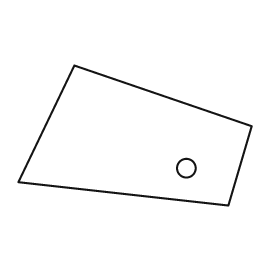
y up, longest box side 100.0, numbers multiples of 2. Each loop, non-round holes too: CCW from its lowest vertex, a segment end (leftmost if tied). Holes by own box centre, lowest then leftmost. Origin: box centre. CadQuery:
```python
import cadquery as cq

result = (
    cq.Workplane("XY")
    .moveTo(40.0, -30.0)
    .lineTo(50.0, 4.0)
    .lineTo(-26.0, 30.0)
    .lineTo(-50.0, -20.0)
    .close()
    .moveTo(22.0, -14.0)
    .circle(4.0)
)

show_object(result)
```